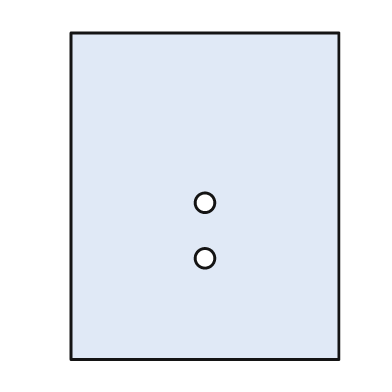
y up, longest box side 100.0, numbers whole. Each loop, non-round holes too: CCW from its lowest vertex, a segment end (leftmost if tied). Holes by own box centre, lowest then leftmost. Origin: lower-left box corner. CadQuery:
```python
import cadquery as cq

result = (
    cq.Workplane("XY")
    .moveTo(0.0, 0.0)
    .lineTo(82.0, 0.0)
    .lineTo(82.0, 100.0)
    .lineTo(0.0, 100.0)
    .close()
    .moveTo(41.0, 31.0)
    .circle(3.0)
    .moveTo(41.0, 48.0)
    .circle(3.0)
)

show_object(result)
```